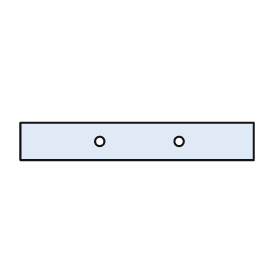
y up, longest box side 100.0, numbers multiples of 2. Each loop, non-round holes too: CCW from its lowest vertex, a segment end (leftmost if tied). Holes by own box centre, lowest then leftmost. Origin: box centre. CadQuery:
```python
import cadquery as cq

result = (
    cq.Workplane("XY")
    .moveTo(-50.0, -8.0)
    .lineTo(50.0, -8.0)
    .lineTo(50.0, 8.0)
    .lineTo(-50.0, 8.0)
    .close()
    .moveTo(-16.0, 0.0)
    .circle(2.0)
    .moveTo(18.0, 0.0)
    .circle(2.0)
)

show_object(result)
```